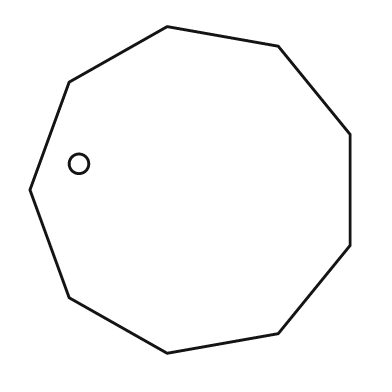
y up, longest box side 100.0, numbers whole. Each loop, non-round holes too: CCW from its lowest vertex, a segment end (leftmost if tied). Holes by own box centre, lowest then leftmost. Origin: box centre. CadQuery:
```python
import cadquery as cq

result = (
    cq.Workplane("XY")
    .moveTo(-7.0, -50.0)
    .lineTo(27.0, -44.0)
    .lineTo(49.0, -17.0)
    .lineTo(49.0, 17.0)
    .lineTo(27.0, 44.0)
    .lineTo(-7.0, 50.0)
    .lineTo(-37.0, 33.0)
    .lineTo(-49.0, 0.0)
    .lineTo(-37.0, -33.0)
    .close()
    .moveTo(-34.0, 8.0)
    .circle(3.0)
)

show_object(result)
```